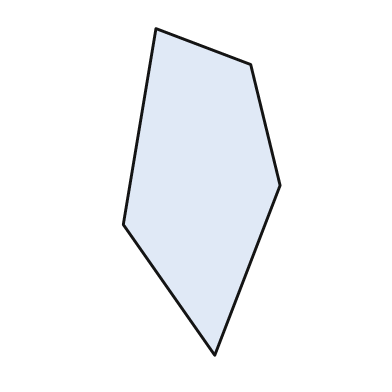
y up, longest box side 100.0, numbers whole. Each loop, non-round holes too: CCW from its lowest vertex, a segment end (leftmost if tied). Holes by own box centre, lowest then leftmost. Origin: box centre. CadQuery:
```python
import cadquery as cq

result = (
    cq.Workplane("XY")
    .moveTo(4.0, -50.0)
    .lineTo(24.0, 2.0)
    .lineTo(15.0, 39.0)
    .lineTo(-14.0, 50.0)
    .lineTo(-24.0, -10.0)
    .close()
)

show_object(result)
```